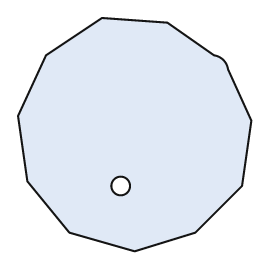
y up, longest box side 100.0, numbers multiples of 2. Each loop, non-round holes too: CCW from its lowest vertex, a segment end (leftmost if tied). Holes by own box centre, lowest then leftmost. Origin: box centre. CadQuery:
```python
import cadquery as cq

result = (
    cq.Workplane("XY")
    .moveTo(0.0, -50.0)
    .lineTo(26.0, -42.0)
    .lineTo(46.0, -22.0)
    .lineTo(50.0, 6.0)
    .lineTo(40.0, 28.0)
    .threePointArc((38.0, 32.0), (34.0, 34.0))
    .lineTo(14.0, 48.0)
    .lineTo(-14.0, 50.0)
    .lineTo(-38.0, 34.0)
    .lineTo(-50.0, 8.0)
    .lineTo(-46.0, -20.0)
    .lineTo(-28.0, -42.0)
    .close()
    .moveTo(-6.0, -22.0)
    .circle(4.0)
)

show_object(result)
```